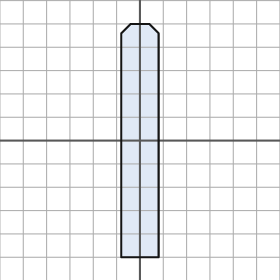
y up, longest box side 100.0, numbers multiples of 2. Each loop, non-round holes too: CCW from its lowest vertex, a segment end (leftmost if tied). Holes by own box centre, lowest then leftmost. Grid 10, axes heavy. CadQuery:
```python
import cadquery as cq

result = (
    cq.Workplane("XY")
    .moveTo(-8.0, -50.0)
    .lineTo(8.0, -50.0)
    .lineTo(8.0, 46.0)
    .lineTo(4.0, 50.0)
    .lineTo(-4.0, 50.0)
    .lineTo(-8.0, 46.0)
    .close()
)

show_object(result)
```